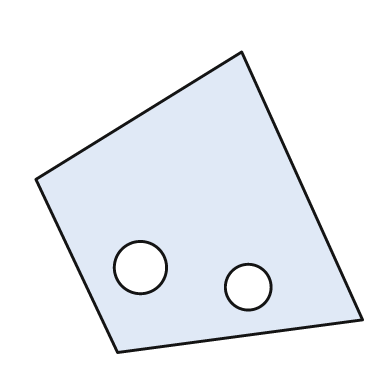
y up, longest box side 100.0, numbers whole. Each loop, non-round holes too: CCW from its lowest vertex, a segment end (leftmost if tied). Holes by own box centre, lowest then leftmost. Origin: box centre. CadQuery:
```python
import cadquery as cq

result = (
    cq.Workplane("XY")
    .moveTo(-25.0, -46.0)
    .lineTo(50.0, -36.0)
    .lineTo(13.0, 46.0)
    .lineTo(-50.0, 7.0)
    .close()
    .moveTo(15.0, -26.0)
    .circle(7.0)
    .moveTo(-18.0, -20.0)
    .circle(8.0)
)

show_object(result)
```